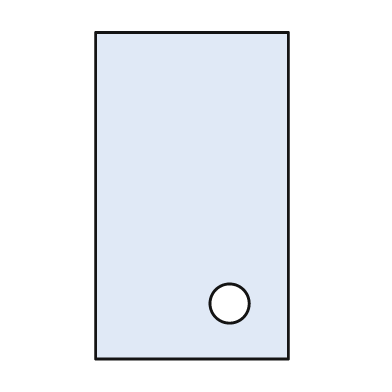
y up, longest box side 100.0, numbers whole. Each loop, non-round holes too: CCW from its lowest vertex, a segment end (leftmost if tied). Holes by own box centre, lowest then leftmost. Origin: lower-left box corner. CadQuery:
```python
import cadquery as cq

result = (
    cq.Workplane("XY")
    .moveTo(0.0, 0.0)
    .lineTo(59.0, 0.0)
    .lineTo(59.0, 100.0)
    .lineTo(0.0, 100.0)
    .close()
    .moveTo(41.0, 17.0)
    .circle(6.0)
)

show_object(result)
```